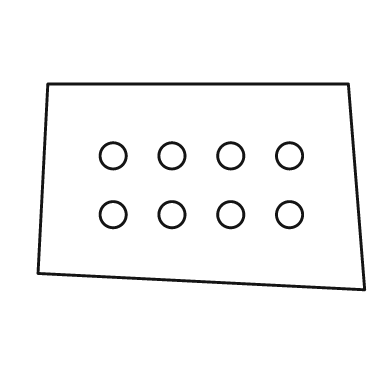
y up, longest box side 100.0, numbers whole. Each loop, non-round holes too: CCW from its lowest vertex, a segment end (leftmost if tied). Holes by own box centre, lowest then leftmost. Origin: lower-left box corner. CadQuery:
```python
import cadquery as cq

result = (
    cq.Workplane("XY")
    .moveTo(100.0, 0.0)
    .lineTo(95.0, 63.0)
    .lineTo(3.0, 63.0)
    .lineTo(0.0, 5.0)
    .close()
    .moveTo(23.0, 23.0)
    .circle(4.0)
    .moveTo(41.0, 23.0)
    .circle(4.0)
    .moveTo(59.0, 23.0)
    .circle(4.0)
    .moveTo(77.0, 23.0)
    .circle(4.0)
    .moveTo(23.0, 41.0)
    .circle(4.0)
    .moveTo(41.0, 41.0)
    .circle(4.0)
    .moveTo(59.0, 41.0)
    .circle(4.0)
    .moveTo(77.0, 41.0)
    .circle(4.0)
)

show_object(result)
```